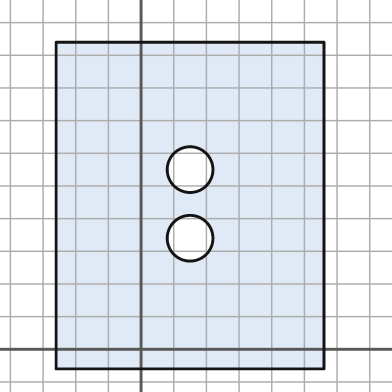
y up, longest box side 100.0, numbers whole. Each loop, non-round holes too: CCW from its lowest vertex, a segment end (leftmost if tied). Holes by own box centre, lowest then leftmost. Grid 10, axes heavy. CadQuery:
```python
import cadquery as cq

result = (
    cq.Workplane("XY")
    .moveTo(-26.0, -6.0)
    .lineTo(56.0, -6.0)
    .lineTo(56.0, 94.0)
    .lineTo(-26.0, 94.0)
    .close()
    .moveTo(15.0, 34.0)
    .circle(7.0)
    .moveTo(15.0, 55.0)
    .circle(7.0)
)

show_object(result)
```